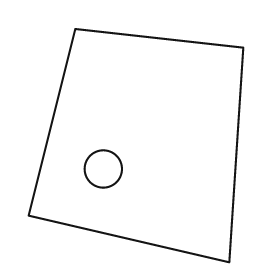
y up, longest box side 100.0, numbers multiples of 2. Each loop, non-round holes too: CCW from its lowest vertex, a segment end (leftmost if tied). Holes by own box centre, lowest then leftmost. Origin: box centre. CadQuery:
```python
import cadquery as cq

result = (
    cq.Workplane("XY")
    .moveTo(40.0, -50.0)
    .lineTo(46.0, 42.0)
    .lineTo(-26.0, 50.0)
    .lineTo(-46.0, -30.0)
    .close()
    .moveTo(-14.0, -10.0)
    .circle(8.0)
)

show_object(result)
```